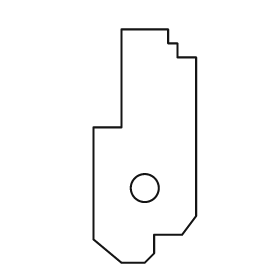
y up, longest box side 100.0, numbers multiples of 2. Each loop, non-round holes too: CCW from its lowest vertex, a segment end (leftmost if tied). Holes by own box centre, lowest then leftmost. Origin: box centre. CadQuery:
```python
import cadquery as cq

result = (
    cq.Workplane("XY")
    .moveTo(-10.0, -50.0)
    .lineTo(0.0, -50.0)
    .lineTo(4.0, -46.0)
    .lineTo(4.0, -38.0)
    .lineTo(16.0, -38.0)
    .lineTo(22.0, -30.0)
    .lineTo(22.0, 38.0)
    .lineTo(14.0, 38.0)
    .lineTo(14.0, 44.0)
    .lineTo(10.0, 44.0)
    .lineTo(10.0, 50.0)
    .lineTo(-10.0, 50.0)
    .lineTo(-10.0, 8.0)
    .lineTo(-22.0, 8.0)
    .lineTo(-22.0, -40.0)
    .close()
    .moveTo(0.0, -18.0)
    .circle(6.0)
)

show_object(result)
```